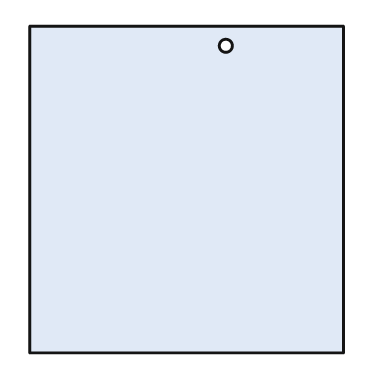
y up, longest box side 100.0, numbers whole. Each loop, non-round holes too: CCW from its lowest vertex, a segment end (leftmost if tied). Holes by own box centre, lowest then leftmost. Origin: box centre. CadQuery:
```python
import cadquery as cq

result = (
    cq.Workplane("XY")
    .moveTo(-48.0, -50.0)
    .lineTo(48.0, -50.0)
    .lineTo(48.0, 50.0)
    .lineTo(-48.0, 50.0)
    .close()
    .moveTo(12.0, 44.0)
    .circle(2.0)
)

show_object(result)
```